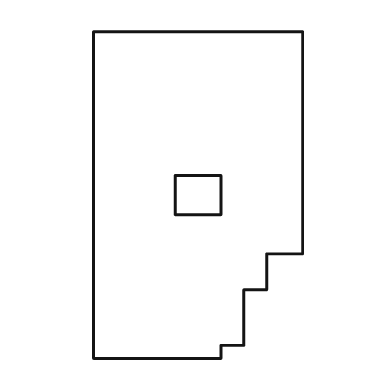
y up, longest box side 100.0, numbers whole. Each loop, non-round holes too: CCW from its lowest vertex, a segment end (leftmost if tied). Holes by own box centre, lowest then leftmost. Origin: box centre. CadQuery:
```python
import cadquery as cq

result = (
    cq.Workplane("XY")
    .moveTo(-32.0, -50.0)
    .lineTo(7.0, -50.0)
    .lineTo(7.0, -46.0)
    .lineTo(14.0, -46.0)
    .lineTo(14.0, -29.0)
    .lineTo(21.0, -29.0)
    .lineTo(21.0, -18.0)
    .lineTo(32.0, -18.0)
    .lineTo(32.0, 50.0)
    .lineTo(-32.0, 50.0)
    .close()
    .moveTo(-7.0, -6.0)
    .lineTo(7.0, -6.0)
    .lineTo(7.0, 6.0)
    .lineTo(-7.0, 6.0)
    .close()
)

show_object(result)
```